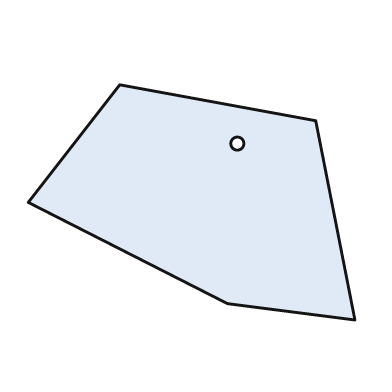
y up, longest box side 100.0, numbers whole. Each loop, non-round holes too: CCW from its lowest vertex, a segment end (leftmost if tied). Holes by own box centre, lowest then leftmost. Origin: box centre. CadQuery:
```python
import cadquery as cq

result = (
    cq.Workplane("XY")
    .moveTo(50.0, -36.0)
    .lineTo(38.0, 25.0)
    .lineTo(-22.0, 36.0)
    .lineTo(-50.0, 0.0)
    .lineTo(11.0, -31.0)
    .close()
    .moveTo(14.0, 18.0)
    .circle(2.0)
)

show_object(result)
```